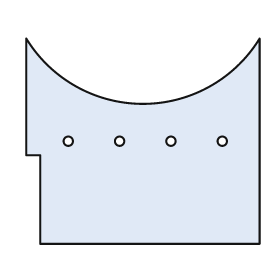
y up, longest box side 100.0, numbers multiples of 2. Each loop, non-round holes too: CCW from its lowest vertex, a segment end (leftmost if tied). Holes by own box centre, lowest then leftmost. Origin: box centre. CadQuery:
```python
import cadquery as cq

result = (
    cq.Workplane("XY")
    .moveTo(-44.0, -44.0)
    .lineTo(50.0, -44.0)
    .lineTo(50.0, 44.0)
    .threePointArc((0.0, 16.0), (-50.0, 44.0))
    .lineTo(-50.0, -6.0)
    .lineTo(-44.0, -6.0)
    .close()
    .moveTo(-32.0, 0.0)
    .circle(2.0)
    .moveTo(-10.0, 0.0)
    .circle(2.0)
    .moveTo(12.0, 0.0)
    .circle(2.0)
    .moveTo(34.0, 0.0)
    .circle(2.0)
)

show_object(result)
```